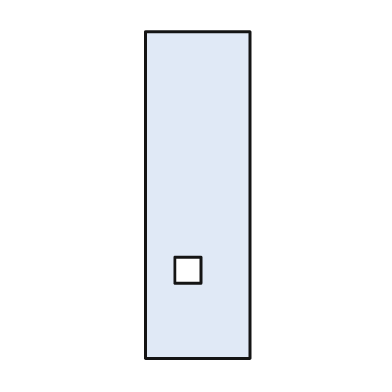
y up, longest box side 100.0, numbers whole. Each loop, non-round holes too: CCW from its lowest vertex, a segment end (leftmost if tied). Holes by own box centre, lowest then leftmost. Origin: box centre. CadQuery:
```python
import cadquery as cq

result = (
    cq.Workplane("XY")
    .moveTo(-16.0, -50.0)
    .lineTo(16.0, -50.0)
    .lineTo(16.0, 50.0)
    .lineTo(-16.0, 50.0)
    .close()
    .moveTo(-7.0, -27.0)
    .lineTo(1.0, -27.0)
    .lineTo(1.0, -19.0)
    .lineTo(-7.0, -19.0)
    .close()
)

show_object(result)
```